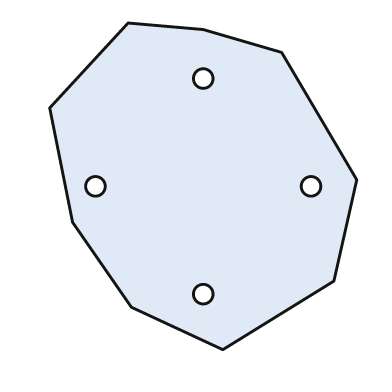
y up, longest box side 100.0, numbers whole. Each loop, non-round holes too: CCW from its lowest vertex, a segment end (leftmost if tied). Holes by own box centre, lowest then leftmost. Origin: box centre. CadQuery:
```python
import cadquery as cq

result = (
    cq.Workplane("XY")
    .moveTo(6.0, -50.0)
    .lineTo(40.0, -29.0)
    .lineTo(47.0, 2.0)
    .lineTo(24.0, 41.0)
    .lineTo(0.0, 48.0)
    .lineTo(-23.0, 50.0)
    .lineTo(-47.0, 24.0)
    .lineTo(-40.0, -11.0)
    .lineTo(-22.0, -37.0)
    .close()
    .moveTo(0.0, -33.0)
    .circle(3.0)
    .moveTo(-33.0, 0.0)
    .circle(3.0)
    .moveTo(33.0, 0.0)
    .circle(3.0)
    .moveTo(0.0, 33.0)
    .circle(3.0)
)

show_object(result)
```